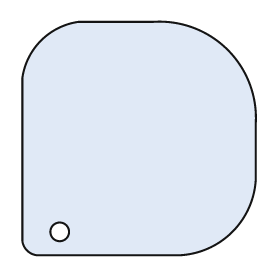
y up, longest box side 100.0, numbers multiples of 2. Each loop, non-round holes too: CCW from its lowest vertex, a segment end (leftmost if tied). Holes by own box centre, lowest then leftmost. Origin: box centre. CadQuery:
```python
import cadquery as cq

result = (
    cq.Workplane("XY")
    .moveTo(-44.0, -50.0)
    .lineTo(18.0, -50.0)
    .threePointArc((40.0, -40.0), (50.0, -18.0))
    .lineTo(50.0, 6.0)
    .threePointArc((38.0, 38.0), (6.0, 50.0))
    .lineTo(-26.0, 50.0)
    .threePointArc((-42.0, 42.0), (-50.0, 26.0))
    .lineTo(-50.0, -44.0)
    .threePointArc((-48.0, -48.0), (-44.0, -50.0))
    .close()
    .moveTo(-34.0, -40.0)
    .circle(4.0)
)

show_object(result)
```